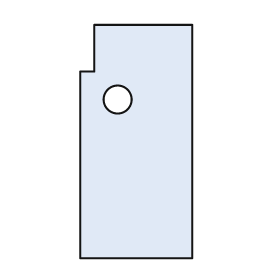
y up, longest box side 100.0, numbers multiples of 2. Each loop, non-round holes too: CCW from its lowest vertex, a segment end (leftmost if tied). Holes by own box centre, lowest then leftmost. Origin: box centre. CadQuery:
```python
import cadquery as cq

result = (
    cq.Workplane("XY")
    .moveTo(-24.0, -50.0)
    .lineTo(24.0, -50.0)
    .lineTo(24.0, 50.0)
    .lineTo(-18.0, 50.0)
    .lineTo(-18.0, 30.0)
    .lineTo(-24.0, 30.0)
    .close()
    .moveTo(-8.0, 18.0)
    .circle(6.0)
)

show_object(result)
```